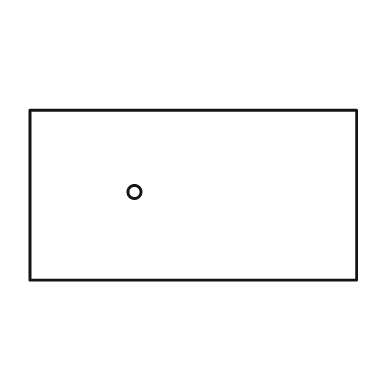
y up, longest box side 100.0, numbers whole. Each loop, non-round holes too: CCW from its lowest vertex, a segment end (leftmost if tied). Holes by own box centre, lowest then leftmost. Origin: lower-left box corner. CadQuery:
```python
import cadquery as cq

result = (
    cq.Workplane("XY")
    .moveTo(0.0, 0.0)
    .lineTo(100.0, 0.0)
    .lineTo(100.0, 52.0)
    .lineTo(0.0, 52.0)
    .close()
    .moveTo(32.0, 27.0)
    .circle(2.0)
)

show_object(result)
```